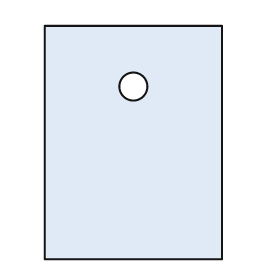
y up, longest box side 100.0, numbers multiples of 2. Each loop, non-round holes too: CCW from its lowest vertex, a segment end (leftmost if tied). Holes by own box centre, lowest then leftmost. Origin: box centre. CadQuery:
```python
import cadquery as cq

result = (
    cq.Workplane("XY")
    .moveTo(-38.0, -50.0)
    .lineTo(38.0, -50.0)
    .lineTo(38.0, 50.0)
    .lineTo(-38.0, 50.0)
    .close()
    .moveTo(0.0, 24.0)
    .circle(6.0)
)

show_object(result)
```